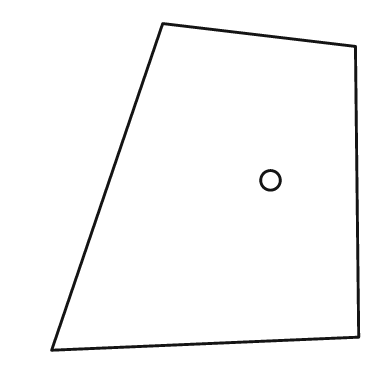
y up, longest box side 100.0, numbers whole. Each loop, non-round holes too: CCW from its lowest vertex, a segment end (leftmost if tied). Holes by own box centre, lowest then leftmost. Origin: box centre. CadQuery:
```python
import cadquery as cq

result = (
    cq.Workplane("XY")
    .moveTo(-47.0, -50.0)
    .lineTo(47.0, -46.0)
    .lineTo(46.0, 43.0)
    .lineTo(-13.0, 50.0)
    .close()
    .moveTo(20.0, 2.0)
    .circle(3.0)
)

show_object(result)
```